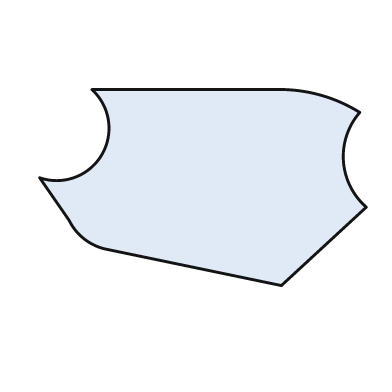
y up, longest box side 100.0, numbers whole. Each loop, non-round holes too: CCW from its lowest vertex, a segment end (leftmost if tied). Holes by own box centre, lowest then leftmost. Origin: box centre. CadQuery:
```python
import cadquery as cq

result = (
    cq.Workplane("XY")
    .moveTo(24.0, -30.0)
    .lineTo(50.0, -6.0)
    .threePointArc((43.0, 8.0), (48.0, 23.0))
    .threePointArc((37.0, 28.0), (25.0, 30.0))
    .lineTo(-34.0, 30.0)
    .threePointArc((-31.0, 10.0), (-50.0, 3.0))
    .lineTo(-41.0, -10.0)
    .threePointArc((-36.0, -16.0), (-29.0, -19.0))
    .close()
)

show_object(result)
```